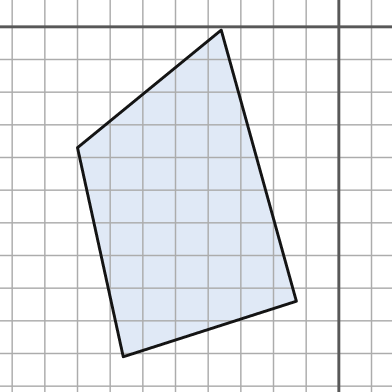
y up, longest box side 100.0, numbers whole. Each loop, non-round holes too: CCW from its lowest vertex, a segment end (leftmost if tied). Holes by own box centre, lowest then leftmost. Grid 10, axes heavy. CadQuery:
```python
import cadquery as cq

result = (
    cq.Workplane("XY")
    .moveTo(-66.0, -101.0)
    .lineTo(-13.0, -84.0)
    .lineTo(-36.0, -1.0)
    .lineTo(-80.0, -37.0)
    .close()
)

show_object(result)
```